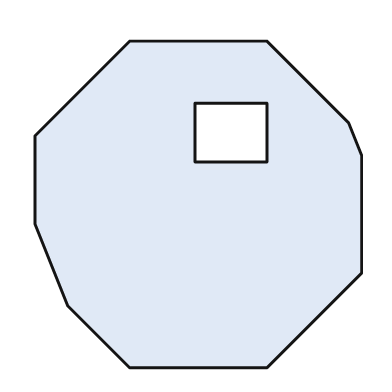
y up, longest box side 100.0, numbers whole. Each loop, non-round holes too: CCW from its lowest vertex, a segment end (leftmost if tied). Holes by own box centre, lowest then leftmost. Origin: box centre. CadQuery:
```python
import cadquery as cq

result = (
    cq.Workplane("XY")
    .moveTo(-21.0, -50.0)
    .lineTo(21.0, -50.0)
    .lineTo(50.0, -21.0)
    .lineTo(50.0, 15.0)
    .lineTo(46.0, 25.0)
    .lineTo(21.0, 50.0)
    .lineTo(-21.0, 50.0)
    .lineTo(-50.0, 21.0)
    .lineTo(-50.0, -6.0)
    .lineTo(-40.0, -31.0)
    .close()
    .moveTo(-1.0, 13.0)
    .lineTo(21.0, 13.0)
    .lineTo(21.0, 31.0)
    .lineTo(-1.0, 31.0)
    .close()
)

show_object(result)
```